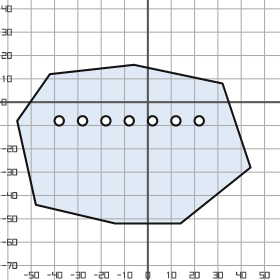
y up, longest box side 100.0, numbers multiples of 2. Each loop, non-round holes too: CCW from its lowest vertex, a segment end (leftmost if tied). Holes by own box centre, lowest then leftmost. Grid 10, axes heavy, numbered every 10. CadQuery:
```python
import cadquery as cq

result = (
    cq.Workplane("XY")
    .moveTo(-14.0, -52.0)
    .lineTo(14.0, -52.0)
    .lineTo(44.0, -28.0)
    .lineTo(32.0, 8.0)
    .lineTo(-6.0, 16.0)
    .lineTo(-42.0, 12.0)
    .lineTo(-56.0, -8.0)
    .lineTo(-48.0, -44.0)
    .close()
    .moveTo(-38.0, -8.0)
    .circle(2.0)
    .moveTo(-28.0, -8.0)
    .circle(2.0)
    .moveTo(-18.0, -8.0)
    .circle(2.0)
    .moveTo(-8.0, -8.0)
    .circle(2.0)
    .moveTo(2.0, -8.0)
    .circle(2.0)
    .moveTo(12.0, -8.0)
    .circle(2.0)
    .moveTo(22.0, -8.0)
    .circle(2.0)
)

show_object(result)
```